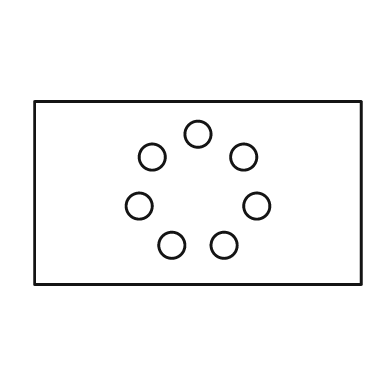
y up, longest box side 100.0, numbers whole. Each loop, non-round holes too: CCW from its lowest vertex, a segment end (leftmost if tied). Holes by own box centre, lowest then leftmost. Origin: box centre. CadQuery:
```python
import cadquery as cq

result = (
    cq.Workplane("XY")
    .moveTo(-50.0, -28.0)
    .lineTo(50.0, -28.0)
    .lineTo(50.0, 28.0)
    .lineTo(-50.0, 28.0)
    .close()
    .moveTo(-8.0, -16.0)
    .circle(4.0)
    .moveTo(8.0, -16.0)
    .circle(4.0)
    .moveTo(-18.0, -4.0)
    .circle(4.0)
    .moveTo(18.0, -4.0)
    .circle(4.0)
    .moveTo(-14.0, 11.0)
    .circle(4.0)
    .moveTo(14.0, 11.0)
    .circle(4.0)
    .moveTo(0.0, 18.0)
    .circle(4.0)
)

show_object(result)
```